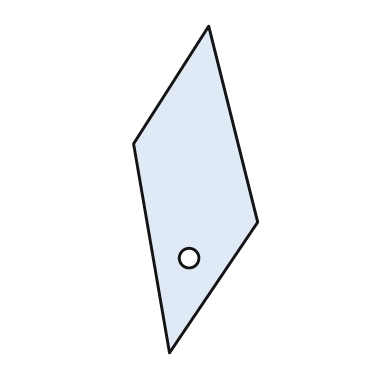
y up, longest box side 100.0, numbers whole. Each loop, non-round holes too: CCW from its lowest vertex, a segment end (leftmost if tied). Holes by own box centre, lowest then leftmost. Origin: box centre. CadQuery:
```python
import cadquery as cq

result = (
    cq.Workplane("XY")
    .moveTo(-8.0, -50.0)
    .lineTo(19.0, -10.0)
    .lineTo(4.0, 50.0)
    .lineTo(-19.0, 14.0)
    .close()
    .moveTo(-2.0, -21.0)
    .circle(3.0)
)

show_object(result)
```